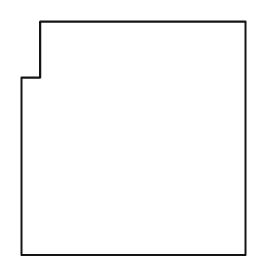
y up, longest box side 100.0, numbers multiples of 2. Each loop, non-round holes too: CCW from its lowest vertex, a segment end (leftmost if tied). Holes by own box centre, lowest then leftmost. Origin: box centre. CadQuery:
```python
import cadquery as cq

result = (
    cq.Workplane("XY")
    .moveTo(-48.0, -50.0)
    .lineTo(48.0, -50.0)
    .lineTo(48.0, 50.0)
    .lineTo(-40.0, 50.0)
    .lineTo(-40.0, 26.0)
    .lineTo(-48.0, 26.0)
    .close()
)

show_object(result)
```